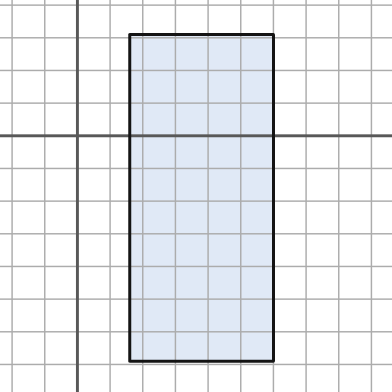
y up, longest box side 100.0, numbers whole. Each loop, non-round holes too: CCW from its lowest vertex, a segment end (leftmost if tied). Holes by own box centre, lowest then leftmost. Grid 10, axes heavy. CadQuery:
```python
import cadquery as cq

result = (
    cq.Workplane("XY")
    .moveTo(16.0, -69.0)
    .lineTo(60.0, -69.0)
    .lineTo(60.0, 31.0)
    .lineTo(16.0, 31.0)
    .close()
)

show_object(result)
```